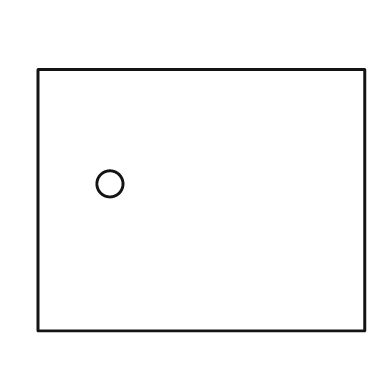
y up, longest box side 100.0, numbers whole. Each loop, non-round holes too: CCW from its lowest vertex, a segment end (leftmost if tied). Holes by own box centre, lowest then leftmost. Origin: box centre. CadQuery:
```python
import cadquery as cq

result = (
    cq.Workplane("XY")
    .moveTo(-50.0, -40.0)
    .lineTo(50.0, -40.0)
    .lineTo(50.0, 40.0)
    .lineTo(-50.0, 40.0)
    .close()
    .moveTo(-28.0, 5.0)
    .circle(4.0)
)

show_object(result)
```